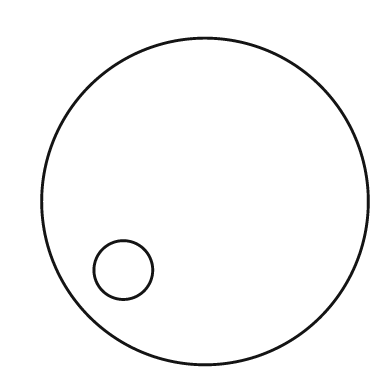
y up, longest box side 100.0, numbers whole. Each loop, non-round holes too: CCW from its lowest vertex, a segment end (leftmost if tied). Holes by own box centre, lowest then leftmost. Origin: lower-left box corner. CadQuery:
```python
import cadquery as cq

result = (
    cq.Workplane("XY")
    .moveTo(50.0, 50.0)
    .circle(50.0)
    .moveTo(25.0, 29.0)
    .circle(9.0)
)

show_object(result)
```